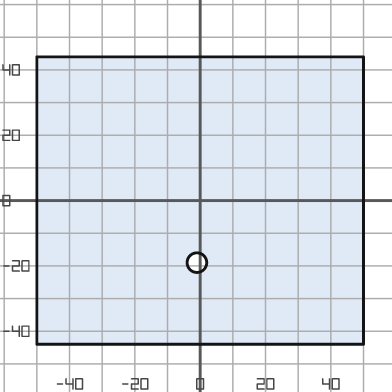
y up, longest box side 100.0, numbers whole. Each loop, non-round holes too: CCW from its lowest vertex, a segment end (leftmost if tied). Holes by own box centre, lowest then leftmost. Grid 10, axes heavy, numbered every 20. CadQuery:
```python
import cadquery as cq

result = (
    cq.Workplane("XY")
    .moveTo(-50.0, -44.0)
    .lineTo(50.0, -44.0)
    .lineTo(50.0, 44.0)
    .lineTo(-50.0, 44.0)
    .close()
    .moveTo(-1.0, -19.0)
    .circle(3.0)
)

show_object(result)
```